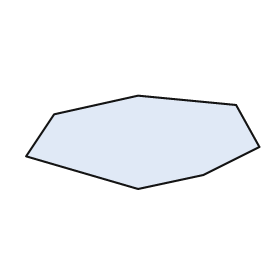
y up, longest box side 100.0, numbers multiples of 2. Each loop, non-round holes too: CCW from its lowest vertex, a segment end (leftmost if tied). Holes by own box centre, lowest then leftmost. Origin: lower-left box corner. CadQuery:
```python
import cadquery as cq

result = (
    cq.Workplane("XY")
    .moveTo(48.0, 0.0)
    .lineTo(76.0, 6.0)
    .lineTo(100.0, 18.0)
    .lineTo(90.0, 36.0)
    .lineTo(48.0, 40.0)
    .lineTo(12.0, 32.0)
    .lineTo(0.0, 14.0)
    .close()
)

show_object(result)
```